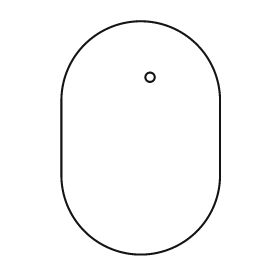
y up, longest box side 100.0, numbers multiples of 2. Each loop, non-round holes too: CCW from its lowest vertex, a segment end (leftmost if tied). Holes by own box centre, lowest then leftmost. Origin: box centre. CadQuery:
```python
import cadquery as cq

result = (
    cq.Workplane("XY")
    .moveTo(-34.0, -16.0)
    .threePointArc((0.0, -50.0), (34.0, -16.0))
    .lineTo(34.0, 16.0)
    .threePointArc((0.0, 50.0), (-34.0, 16.0))
    .close()
    .moveTo(4.0, 26.0)
    .circle(2.0)
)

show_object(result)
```